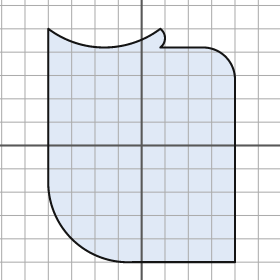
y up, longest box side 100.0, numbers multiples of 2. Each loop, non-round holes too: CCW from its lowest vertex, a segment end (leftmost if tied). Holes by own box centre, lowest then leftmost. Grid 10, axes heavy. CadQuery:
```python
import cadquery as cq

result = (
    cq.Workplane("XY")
    .moveTo(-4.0, -50.0)
    .lineTo(40.0, -50.0)
    .lineTo(40.0, 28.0)
    .threePointArc((36.0, 38.0), (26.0, 42.0))
    .lineTo(8.0, 42.0)
    .threePointArc((10.0, 46.0), (8.0, 50.0))
    .threePointArc((-16.0, 42.0), (-40.0, 50.0))
    .lineTo(-40.0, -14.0)
    .threePointArc((-30.0, -40.0), (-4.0, -50.0))
    .close()
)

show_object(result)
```